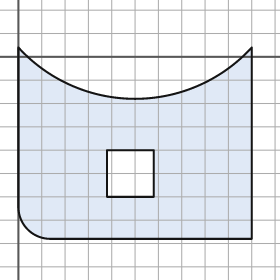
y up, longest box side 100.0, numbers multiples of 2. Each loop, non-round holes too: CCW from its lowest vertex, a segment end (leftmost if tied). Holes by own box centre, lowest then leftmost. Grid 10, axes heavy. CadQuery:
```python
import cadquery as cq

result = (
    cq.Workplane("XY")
    .moveTo(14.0, -78.0)
    .lineTo(100.0, -78.0)
    .lineTo(100.0, 4.0)
    .threePointArc((50.0, -18.0), (0.0, 4.0))
    .lineTo(0.0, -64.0)
    .threePointArc((4.0, -74.0), (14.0, -78.0))
    .close()
    .moveTo(38.0, -60.0)
    .lineTo(58.0, -60.0)
    .lineTo(58.0, -40.0)
    .lineTo(38.0, -40.0)
    .close()
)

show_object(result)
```